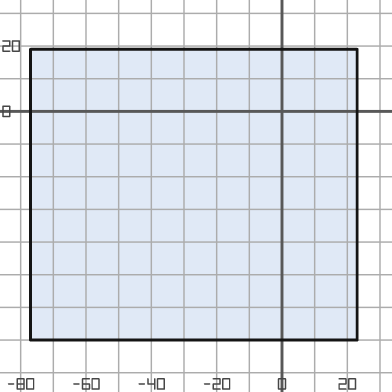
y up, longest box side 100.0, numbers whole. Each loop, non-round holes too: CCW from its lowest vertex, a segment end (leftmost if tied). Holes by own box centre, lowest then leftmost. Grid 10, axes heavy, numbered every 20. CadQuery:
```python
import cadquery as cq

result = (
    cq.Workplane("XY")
    .moveTo(-77.0, -70.0)
    .lineTo(23.0, -70.0)
    .lineTo(23.0, 19.0)
    .lineTo(-77.0, 19.0)
    .close()
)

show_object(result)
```